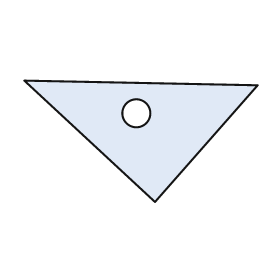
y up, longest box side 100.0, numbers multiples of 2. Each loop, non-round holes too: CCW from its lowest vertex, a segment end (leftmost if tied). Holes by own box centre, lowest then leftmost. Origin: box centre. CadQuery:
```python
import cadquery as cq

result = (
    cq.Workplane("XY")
    .moveTo(6.0, -26.0)
    .lineTo(50.0, 24.0)
    .lineTo(-50.0, 26.0)
    .close()
    .moveTo(-2.0, 12.0)
    .circle(6.0)
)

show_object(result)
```